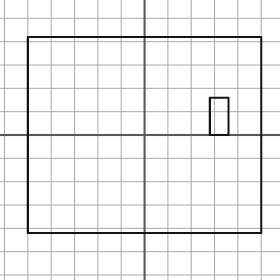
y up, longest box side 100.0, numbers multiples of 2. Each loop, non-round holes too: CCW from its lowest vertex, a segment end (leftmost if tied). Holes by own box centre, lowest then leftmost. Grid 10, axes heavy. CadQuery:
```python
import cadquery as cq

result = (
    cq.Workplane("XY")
    .moveTo(-50.0, -42.0)
    .lineTo(50.0, -42.0)
    .lineTo(50.0, 42.0)
    .lineTo(-50.0, 42.0)
    .close()
    .moveTo(28.0, 0.0)
    .lineTo(36.0, 0.0)
    .lineTo(36.0, 16.0)
    .lineTo(28.0, 16.0)
    .close()
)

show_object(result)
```